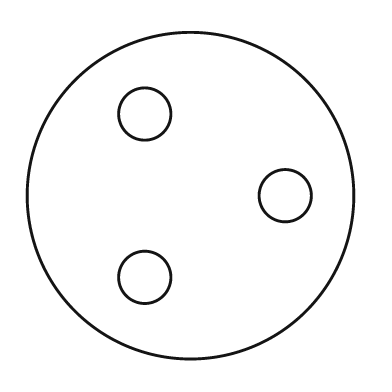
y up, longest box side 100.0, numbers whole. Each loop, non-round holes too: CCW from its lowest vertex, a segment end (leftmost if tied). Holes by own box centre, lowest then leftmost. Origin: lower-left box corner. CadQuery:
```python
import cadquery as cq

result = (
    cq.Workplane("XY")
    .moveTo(50.0, 50.0)
    .circle(50.0)
    .moveTo(36.0, 25.0)
    .circle(8.0)
    .moveTo(79.0, 50.0)
    .circle(8.0)
    .moveTo(36.0, 75.0)
    .circle(8.0)
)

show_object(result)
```